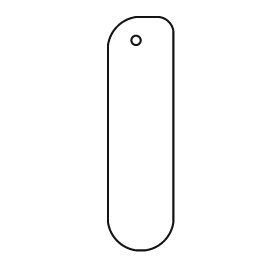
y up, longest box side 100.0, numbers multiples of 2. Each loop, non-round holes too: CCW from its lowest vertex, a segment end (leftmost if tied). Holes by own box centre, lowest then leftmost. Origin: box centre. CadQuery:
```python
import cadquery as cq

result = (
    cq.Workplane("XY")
    .moveTo(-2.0, -50.0)
    .lineTo(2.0, -50.0)
    .threePointArc((10.0, -46.0), (14.0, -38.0))
    .lineTo(14.0, 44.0)
    .threePointArc((12.0, 48.0), (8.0, 50.0))
    .lineTo(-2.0, 50.0)
    .threePointArc((-10.0, 46.0), (-14.0, 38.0))
    .lineTo(-14.0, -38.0)
    .threePointArc((-10.0, -46.0), (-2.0, -50.0))
    .close()
    .moveTo(-2.0, 40.0)
    .circle(2.0)
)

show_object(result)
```